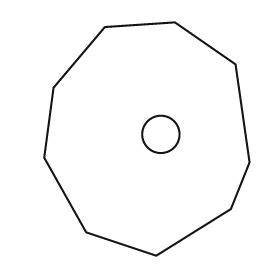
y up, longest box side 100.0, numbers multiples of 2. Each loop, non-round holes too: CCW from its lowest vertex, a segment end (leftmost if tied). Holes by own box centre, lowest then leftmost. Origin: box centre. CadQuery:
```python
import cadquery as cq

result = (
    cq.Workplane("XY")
    .moveTo(4.0, -50.0)
    .lineTo(36.0, -30.0)
    .lineTo(44.0, -10.0)
    .lineTo(38.0, 32.0)
    .lineTo(12.0, 50.0)
    .lineTo(-18.0, 48.0)
    .lineTo(-40.0, 22.0)
    .lineTo(-44.0, -8.0)
    .lineTo(-26.0, -40.0)
    .close()
    .moveTo(6.0, 2.0)
    .circle(8.0)
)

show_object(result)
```